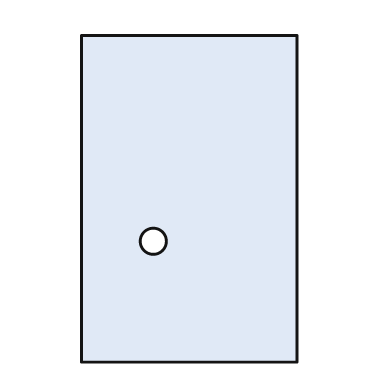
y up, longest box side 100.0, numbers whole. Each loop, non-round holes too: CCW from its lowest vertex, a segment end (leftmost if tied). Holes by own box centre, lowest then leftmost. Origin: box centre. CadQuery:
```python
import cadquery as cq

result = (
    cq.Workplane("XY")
    .moveTo(-33.0, -50.0)
    .lineTo(33.0, -50.0)
    .lineTo(33.0, 50.0)
    .lineTo(-33.0, 50.0)
    .close()
    .moveTo(-11.0, -13.0)
    .circle(4.0)
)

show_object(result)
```